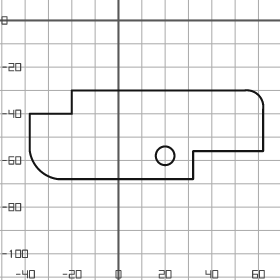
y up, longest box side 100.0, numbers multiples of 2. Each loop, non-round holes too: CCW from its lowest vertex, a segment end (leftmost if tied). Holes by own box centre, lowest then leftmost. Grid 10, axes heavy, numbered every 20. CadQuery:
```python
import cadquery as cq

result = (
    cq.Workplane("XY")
    .moveTo(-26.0, -68.0)
    .lineTo(32.0, -68.0)
    .lineTo(32.0, -56.0)
    .lineTo(62.0, -56.0)
    .lineTo(62.0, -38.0)
    .threePointArc((60.0, -32.0), (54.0, -30.0))
    .lineTo(-20.0, -30.0)
    .lineTo(-20.0, -40.0)
    .lineTo(-38.0, -40.0)
    .lineTo(-38.0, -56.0)
    .threePointArc((-34.0, -64.0), (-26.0, -68.0))
    .close()
    .moveTo(20.0, -58.0)
    .circle(4.0)
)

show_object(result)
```